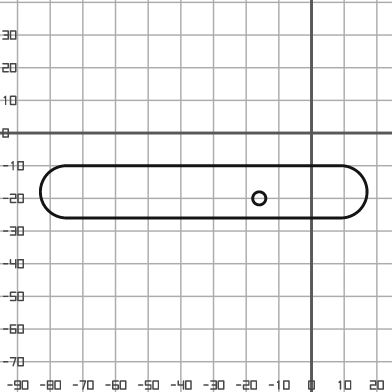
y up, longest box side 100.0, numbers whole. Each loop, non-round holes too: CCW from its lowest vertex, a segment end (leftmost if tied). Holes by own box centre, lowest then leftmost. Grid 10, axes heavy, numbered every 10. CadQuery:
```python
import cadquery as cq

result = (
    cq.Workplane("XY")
    .moveTo(-75.0, -26.0)
    .lineTo(9.0, -26.0)
    .threePointArc((17.0, -18.0), (9.0, -10.0))
    .lineTo(-75.0, -10.0)
    .threePointArc((-83.0, -18.0), (-75.0, -26.0))
    .close()
    .moveTo(-16.0, -20.0)
    .circle(2.0)
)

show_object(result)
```